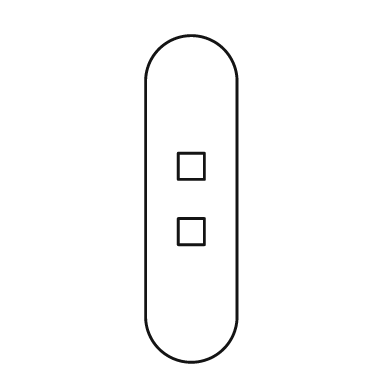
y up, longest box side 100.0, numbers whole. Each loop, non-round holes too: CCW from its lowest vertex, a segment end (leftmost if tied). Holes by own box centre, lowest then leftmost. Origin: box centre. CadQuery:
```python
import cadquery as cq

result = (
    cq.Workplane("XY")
    .moveTo(-14.0, -36.0)
    .threePointArc((0.0, -50.0), (14.0, -36.0))
    .lineTo(14.0, 36.0)
    .threePointArc((0.0, 50.0), (-14.0, 36.0))
    .close()
    .moveTo(-4.0, -14.0)
    .lineTo(4.0, -14.0)
    .lineTo(4.0, -6.0)
    .lineTo(-4.0, -6.0)
    .close()
    .moveTo(-4.0, 6.0)
    .lineTo(4.0, 6.0)
    .lineTo(4.0, 14.0)
    .lineTo(-4.0, 14.0)
    .close()
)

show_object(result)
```